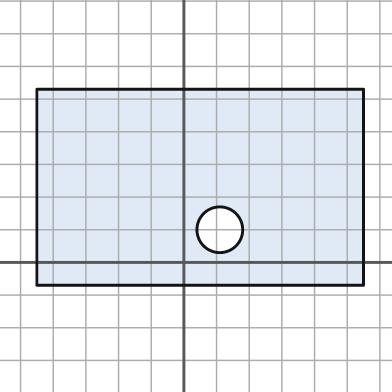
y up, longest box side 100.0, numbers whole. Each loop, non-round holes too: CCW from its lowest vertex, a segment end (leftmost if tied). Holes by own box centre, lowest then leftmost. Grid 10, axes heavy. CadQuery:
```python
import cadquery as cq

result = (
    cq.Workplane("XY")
    .moveTo(-45.0, -7.0)
    .lineTo(55.0, -7.0)
    .lineTo(55.0, 53.0)
    .lineTo(-45.0, 53.0)
    .close()
    .moveTo(11.0, 10.0)
    .circle(7.0)
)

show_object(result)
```